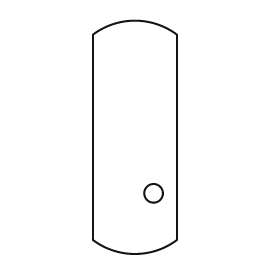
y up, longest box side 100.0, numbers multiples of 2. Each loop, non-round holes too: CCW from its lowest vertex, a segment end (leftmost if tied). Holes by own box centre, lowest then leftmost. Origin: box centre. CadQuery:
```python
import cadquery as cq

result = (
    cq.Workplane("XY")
    .moveTo(-18.0, -44.0)
    .threePointArc((0.0, -50.0), (18.0, -44.0))
    .lineTo(18.0, 44.0)
    .threePointArc((0.0, 50.0), (-18.0, 44.0))
    .close()
    .moveTo(8.0, -24.0)
    .circle(4.0)
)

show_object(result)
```